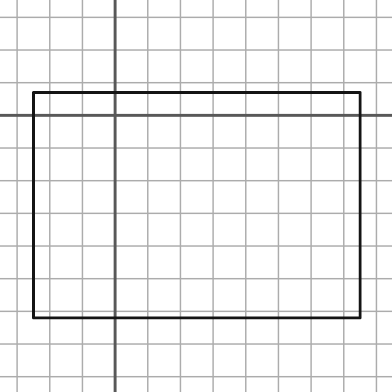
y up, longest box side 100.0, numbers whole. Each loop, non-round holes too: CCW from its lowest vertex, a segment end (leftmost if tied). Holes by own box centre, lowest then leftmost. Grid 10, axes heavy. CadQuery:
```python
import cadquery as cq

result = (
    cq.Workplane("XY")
    .moveTo(-25.0, -62.0)
    .lineTo(75.0, -62.0)
    .lineTo(75.0, 7.0)
    .lineTo(-25.0, 7.0)
    .close()
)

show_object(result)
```